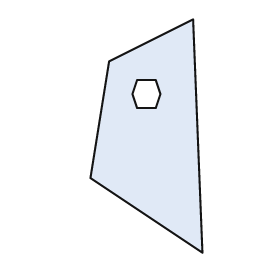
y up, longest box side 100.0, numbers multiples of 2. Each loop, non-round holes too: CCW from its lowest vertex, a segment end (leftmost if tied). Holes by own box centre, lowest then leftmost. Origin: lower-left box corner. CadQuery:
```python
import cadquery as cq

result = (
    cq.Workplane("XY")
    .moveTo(48.0, 0.0)
    .lineTo(44.0, 100.0)
    .lineTo(8.0, 82.0)
    .lineTo(0.0, 32.0)
    .close()
    .moveTo(20.0, 62.0)
    .lineTo(28.0, 62.0)
    .lineTo(30.0, 68.0)
    .lineTo(28.0, 74.0)
    .lineTo(20.0, 74.0)
    .lineTo(18.0, 68.0)
    .close()
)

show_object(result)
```